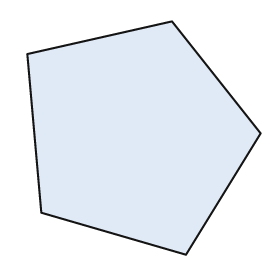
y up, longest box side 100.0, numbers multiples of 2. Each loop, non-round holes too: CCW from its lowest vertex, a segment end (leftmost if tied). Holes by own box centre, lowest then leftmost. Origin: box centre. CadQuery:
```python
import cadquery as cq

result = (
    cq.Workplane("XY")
    .moveTo(18.0, -50.0)
    .lineTo(50.0, 2.0)
    .lineTo(12.0, 50.0)
    .lineTo(-50.0, 36.0)
    .lineTo(-44.0, -32.0)
    .close()
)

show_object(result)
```